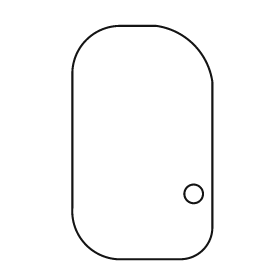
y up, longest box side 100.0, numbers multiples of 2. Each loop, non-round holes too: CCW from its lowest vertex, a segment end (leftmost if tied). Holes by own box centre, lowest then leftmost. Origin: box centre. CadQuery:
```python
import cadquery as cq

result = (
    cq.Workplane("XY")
    .moveTo(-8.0, -50.0)
    .lineTo(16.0, -50.0)
    .threePointArc((26.0, -46.0), (30.0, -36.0))
    .lineTo(30.0, 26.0)
    .threePointArc((22.0, 42.0), (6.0, 50.0))
    .lineTo(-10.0, 50.0)
    .threePointArc((-24.0, 44.0), (-30.0, 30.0))
    .lineTo(-30.0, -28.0)
    .threePointArc((-24.0, -44.0), (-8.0, -50.0))
    .close()
    .moveTo(22.0, -22.0)
    .circle(4.0)
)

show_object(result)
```